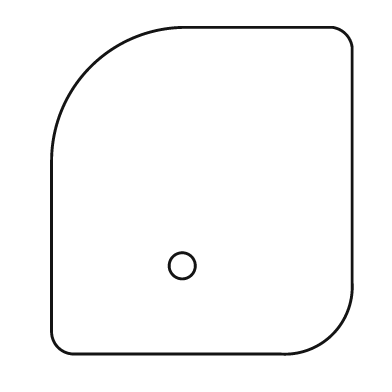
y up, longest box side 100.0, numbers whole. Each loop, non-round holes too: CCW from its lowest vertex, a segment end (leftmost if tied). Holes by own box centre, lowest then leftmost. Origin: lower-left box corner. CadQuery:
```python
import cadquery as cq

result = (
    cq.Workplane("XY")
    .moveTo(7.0, 0.0)
    .lineTo(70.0, 0.0)
    .threePointArc((86.0, 6.0), (92.0, 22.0))
    .lineTo(92.0, 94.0)
    .threePointArc((90.0, 98.0), (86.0, 100.0))
    .lineTo(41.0, 100.0)
    .threePointArc((12.0, 88.0), (0.0, 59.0))
    .lineTo(0.0, 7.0)
    .threePointArc((2.0, 2.0), (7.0, 0.0))
    .close()
    .moveTo(40.0, 27.0)
    .circle(4.0)
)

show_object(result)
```